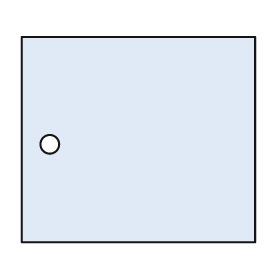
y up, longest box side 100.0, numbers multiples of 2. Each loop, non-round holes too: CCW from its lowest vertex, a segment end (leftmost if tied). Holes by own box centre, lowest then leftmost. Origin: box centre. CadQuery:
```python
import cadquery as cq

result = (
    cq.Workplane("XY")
    .moveTo(-50.0, -44.0)
    .lineTo(50.0, -44.0)
    .lineTo(50.0, 44.0)
    .lineTo(-50.0, 44.0)
    .close()
    .moveTo(-38.0, -2.0)
    .circle(4.0)
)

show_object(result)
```